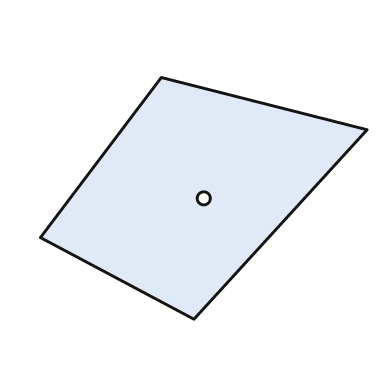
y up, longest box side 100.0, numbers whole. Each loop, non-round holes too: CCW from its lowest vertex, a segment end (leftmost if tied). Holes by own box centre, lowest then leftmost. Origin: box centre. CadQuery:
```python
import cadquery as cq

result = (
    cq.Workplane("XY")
    .moveTo(-3.0, -37.0)
    .lineTo(50.0, 21.0)
    .lineTo(-13.0, 37.0)
    .lineTo(-50.0, -12.0)
    .close()
    .moveTo(0.0, 0.0)
    .circle(2.0)
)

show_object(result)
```